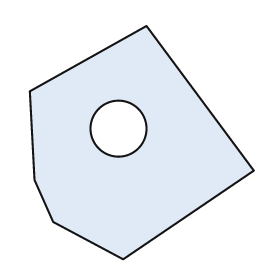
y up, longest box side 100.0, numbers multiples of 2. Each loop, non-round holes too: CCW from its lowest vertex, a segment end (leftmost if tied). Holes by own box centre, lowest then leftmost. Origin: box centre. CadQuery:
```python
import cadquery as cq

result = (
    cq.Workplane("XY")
    .moveTo(-8.0, -50.0)
    .lineTo(48.0, -12.0)
    .lineTo(2.0, 50.0)
    .lineTo(-48.0, 22.0)
    .lineTo(-46.0, -16.0)
    .lineTo(-38.0, -34.0)
    .close()
    .moveTo(-10.0, 6.0)
    .circle(12.0)
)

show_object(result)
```